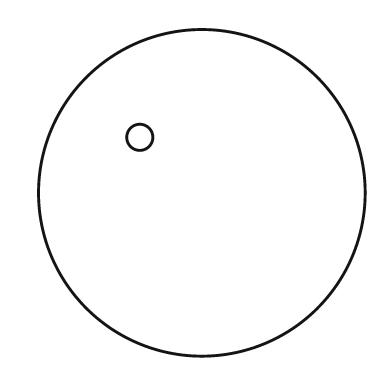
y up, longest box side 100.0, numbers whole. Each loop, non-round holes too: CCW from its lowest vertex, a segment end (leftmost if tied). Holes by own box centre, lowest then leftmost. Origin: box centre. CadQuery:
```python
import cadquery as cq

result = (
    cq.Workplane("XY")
    .moveTo(0.0, 0.0)
    .circle(50.0)
    .moveTo(-19.0, 17.0)
    .circle(4.0)
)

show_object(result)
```